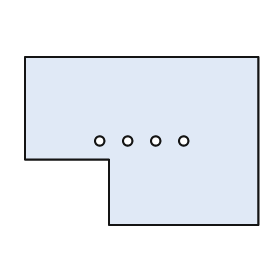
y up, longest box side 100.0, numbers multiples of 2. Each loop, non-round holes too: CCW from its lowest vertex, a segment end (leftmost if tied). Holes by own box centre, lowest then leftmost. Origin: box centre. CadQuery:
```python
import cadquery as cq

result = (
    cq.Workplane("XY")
    .moveTo(-14.0, -36.0)
    .lineTo(50.0, -36.0)
    .lineTo(50.0, 36.0)
    .lineTo(-50.0, 36.0)
    .lineTo(-50.0, -8.0)
    .lineTo(-14.0, -8.0)
    .close()
    .moveTo(-18.0, 0.0)
    .circle(2.0)
    .moveTo(-6.0, 0.0)
    .circle(2.0)
    .moveTo(6.0, 0.0)
    .circle(2.0)
    .moveTo(18.0, 0.0)
    .circle(2.0)
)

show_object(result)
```